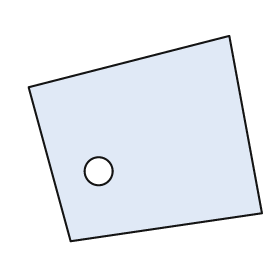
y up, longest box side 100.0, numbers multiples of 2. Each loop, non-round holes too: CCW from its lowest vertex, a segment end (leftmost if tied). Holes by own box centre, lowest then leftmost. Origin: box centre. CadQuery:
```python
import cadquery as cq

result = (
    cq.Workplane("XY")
    .moveTo(-32.0, -44.0)
    .lineTo(50.0, -32.0)
    .lineTo(36.0, 44.0)
    .lineTo(-50.0, 22.0)
    .close()
    .moveTo(-20.0, -14.0)
    .circle(6.0)
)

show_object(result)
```